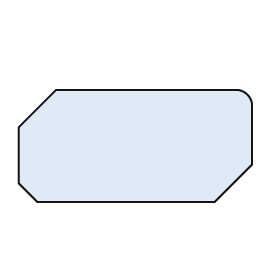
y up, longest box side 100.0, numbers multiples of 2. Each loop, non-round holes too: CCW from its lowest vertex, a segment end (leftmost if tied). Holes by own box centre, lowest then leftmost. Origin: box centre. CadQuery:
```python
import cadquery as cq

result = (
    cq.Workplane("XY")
    .moveTo(-42.0, -24.0)
    .lineTo(34.0, -24.0)
    .lineTo(50.0, -8.0)
    .lineTo(50.0, 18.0)
    .threePointArc((48.0, 22.0), (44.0, 24.0))
    .lineTo(-34.0, 24.0)
    .lineTo(-50.0, 8.0)
    .lineTo(-50.0, -16.0)
    .close()
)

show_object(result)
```